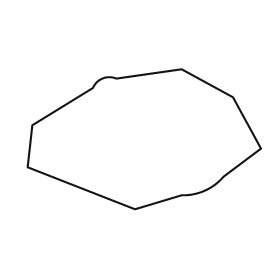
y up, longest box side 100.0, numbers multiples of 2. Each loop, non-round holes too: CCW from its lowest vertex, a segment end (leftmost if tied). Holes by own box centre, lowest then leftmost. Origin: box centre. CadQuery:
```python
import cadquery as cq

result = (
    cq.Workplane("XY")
    .moveTo(-4.0, -30.0)
    .lineTo(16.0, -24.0)
    .threePointArc((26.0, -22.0), (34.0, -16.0))
    .lineTo(50.0, -4.0)
    .lineTo(38.0, 18.0)
    .lineTo(16.0, 30.0)
    .lineTo(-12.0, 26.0)
    .threePointArc((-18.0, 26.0), (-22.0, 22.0))
    .lineTo(-48.0, 6.0)
    .lineTo(-50.0, -12.0)
    .close()
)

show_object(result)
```